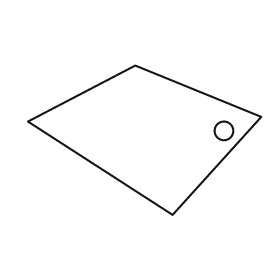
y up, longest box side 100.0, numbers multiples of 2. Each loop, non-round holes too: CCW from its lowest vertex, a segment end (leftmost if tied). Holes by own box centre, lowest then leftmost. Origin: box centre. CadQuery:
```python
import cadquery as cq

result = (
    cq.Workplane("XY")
    .moveTo(12.0, -32.0)
    .lineTo(50.0, 10.0)
    .lineTo(-4.0, 32.0)
    .lineTo(-50.0, 8.0)
    .close()
    .moveTo(34.0, 4.0)
    .circle(4.0)
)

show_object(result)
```